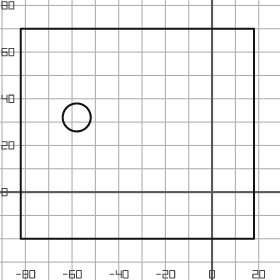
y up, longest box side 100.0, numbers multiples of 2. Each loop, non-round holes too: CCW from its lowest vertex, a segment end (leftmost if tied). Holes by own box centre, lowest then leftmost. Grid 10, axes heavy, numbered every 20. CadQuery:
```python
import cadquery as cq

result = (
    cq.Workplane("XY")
    .moveTo(-82.0, -20.0)
    .lineTo(18.0, -20.0)
    .lineTo(18.0, 70.0)
    .lineTo(-82.0, 70.0)
    .close()
    .moveTo(-58.0, 32.0)
    .circle(6.0)
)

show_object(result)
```